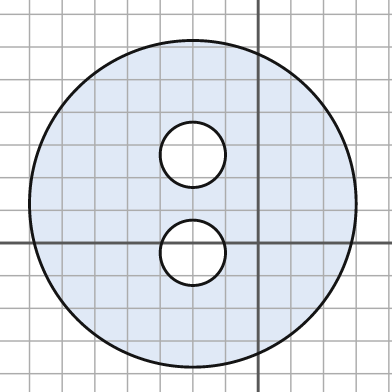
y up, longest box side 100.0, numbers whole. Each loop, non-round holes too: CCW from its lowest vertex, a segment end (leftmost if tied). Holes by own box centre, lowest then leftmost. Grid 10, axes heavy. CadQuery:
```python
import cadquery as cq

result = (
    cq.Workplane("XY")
    .moveTo(-20.0, 12.0)
    .circle(50.0)
    .moveTo(-20.0, -3.0)
    .circle(10.0)
    .moveTo(-20.0, 27.0)
    .circle(10.0)
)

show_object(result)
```